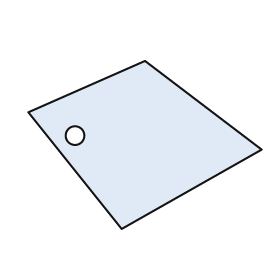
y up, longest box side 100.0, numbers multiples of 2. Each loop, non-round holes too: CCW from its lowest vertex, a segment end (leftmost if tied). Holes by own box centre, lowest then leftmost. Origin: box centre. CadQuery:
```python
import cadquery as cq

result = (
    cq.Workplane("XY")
    .moveTo(-10.0, -36.0)
    .lineTo(50.0, -2.0)
    .lineTo(0.0, 36.0)
    .lineTo(-50.0, 14.0)
    .close()
    .moveTo(-30.0, 4.0)
    .circle(4.0)
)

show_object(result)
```